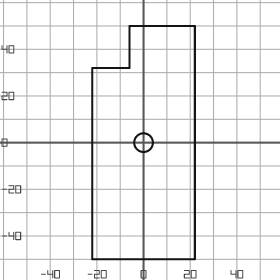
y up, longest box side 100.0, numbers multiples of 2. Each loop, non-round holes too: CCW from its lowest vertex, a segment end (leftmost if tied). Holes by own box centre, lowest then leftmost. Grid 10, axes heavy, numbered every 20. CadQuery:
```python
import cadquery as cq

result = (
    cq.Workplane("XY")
    .moveTo(-22.0, -50.0)
    .lineTo(22.0, -50.0)
    .lineTo(22.0, 50.0)
    .lineTo(-6.0, 50.0)
    .lineTo(-6.0, 32.0)
    .lineTo(-22.0, 32.0)
    .close()
    .moveTo(0.0, 0.0)
    .circle(4.0)
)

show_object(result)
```